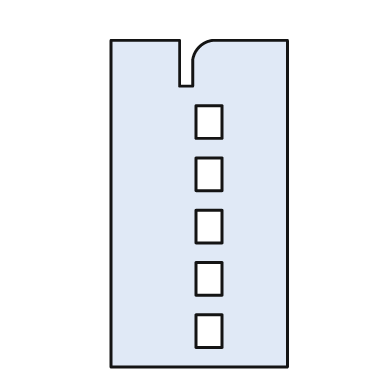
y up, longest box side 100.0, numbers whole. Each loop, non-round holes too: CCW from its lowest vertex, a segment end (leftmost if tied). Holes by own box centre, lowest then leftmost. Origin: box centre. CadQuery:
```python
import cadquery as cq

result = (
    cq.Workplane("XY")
    .moveTo(-27.0, -50.0)
    .lineTo(27.0, -50.0)
    .lineTo(27.0, 50.0)
    .lineTo(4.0, 50.0)
    .threePointArc((0.0, 48.0), (-2.0, 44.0))
    .lineTo(-2.0, 36.0)
    .lineTo(-6.0, 36.0)
    .lineTo(-6.0, 50.0)
    .lineTo(-27.0, 50.0)
    .close()
    .moveTo(-1.0, -44.0)
    .lineTo(7.0, -44.0)
    .lineTo(7.0, -34.0)
    .lineTo(-1.0, -34.0)
    .close()
    .moveTo(-1.0, -28.0)
    .lineTo(7.0, -28.0)
    .lineTo(7.0, -18.0)
    .lineTo(-1.0, -18.0)
    .close()
    .moveTo(-1.0, -12.0)
    .lineTo(7.0, -12.0)
    .lineTo(7.0, -2.0)
    .lineTo(-1.0, -2.0)
    .close()
    .moveTo(-1.0, 4.0)
    .lineTo(7.0, 4.0)
    .lineTo(7.0, 14.0)
    .lineTo(-1.0, 14.0)
    .close()
    .moveTo(-1.0, 20.0)
    .lineTo(7.0, 20.0)
    .lineTo(7.0, 30.0)
    .lineTo(-1.0, 30.0)
    .close()
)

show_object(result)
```